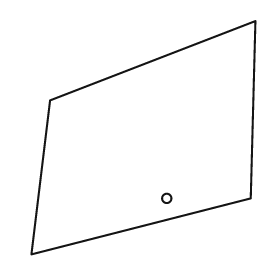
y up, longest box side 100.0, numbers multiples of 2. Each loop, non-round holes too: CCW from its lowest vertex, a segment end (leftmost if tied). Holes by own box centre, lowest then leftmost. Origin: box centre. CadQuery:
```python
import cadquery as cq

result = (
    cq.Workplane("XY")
    .moveTo(-48.0, -50.0)
    .lineTo(46.0, -26.0)
    .lineTo(48.0, 50.0)
    .lineTo(-40.0, 16.0)
    .close()
    .moveTo(10.0, -26.0)
    .circle(2.0)
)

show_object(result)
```